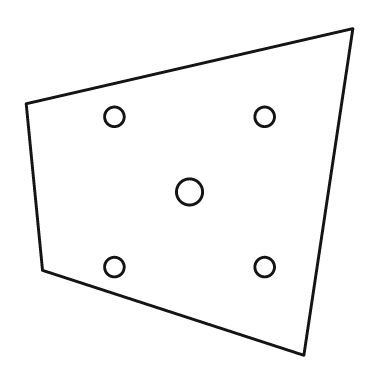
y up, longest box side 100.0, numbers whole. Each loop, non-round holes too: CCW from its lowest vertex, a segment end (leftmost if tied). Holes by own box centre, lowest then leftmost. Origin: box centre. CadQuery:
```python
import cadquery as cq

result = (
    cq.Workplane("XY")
    .moveTo(35.0, -50.0)
    .lineTo(50.0, 50.0)
    .lineTo(-50.0, 27.0)
    .lineTo(-45.0, -24.0)
    .close()
    .moveTo(-23.0, -23.0)
    .circle(3.0)
    .moveTo(23.0, -23.0)
    .circle(3.0)
    .moveTo(0.0, 0.0)
    .circle(4.0)
    .moveTo(-23.0, 23.0)
    .circle(3.0)
    .moveTo(23.0, 23.0)
    .circle(3.0)
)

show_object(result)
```